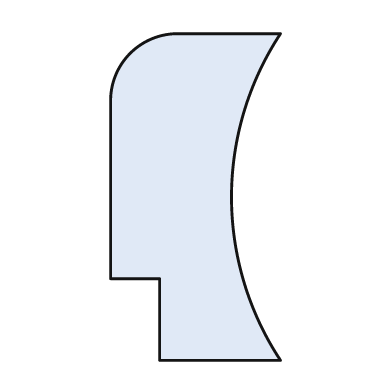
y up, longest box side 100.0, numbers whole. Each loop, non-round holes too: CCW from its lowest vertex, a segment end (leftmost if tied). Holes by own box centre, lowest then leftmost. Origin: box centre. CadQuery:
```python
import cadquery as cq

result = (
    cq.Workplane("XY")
    .moveTo(-11.0, -50.0)
    .lineTo(26.0, -50.0)
    .threePointArc((11.0, 0.0), (26.0, 50.0))
    .lineTo(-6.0, 50.0)
    .threePointArc((-20.0, 44.0), (-26.0, 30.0))
    .lineTo(-26.0, -25.0)
    .lineTo(-11.0, -25.0)
    .close()
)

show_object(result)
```